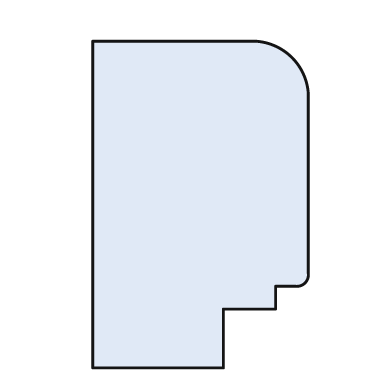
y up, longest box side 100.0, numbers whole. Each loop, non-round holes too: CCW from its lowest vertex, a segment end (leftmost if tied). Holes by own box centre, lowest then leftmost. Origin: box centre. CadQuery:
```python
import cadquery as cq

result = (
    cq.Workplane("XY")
    .moveTo(-33.0, -50.0)
    .lineTo(7.0, -50.0)
    .lineTo(7.0, -32.0)
    .lineTo(23.0, -32.0)
    .lineTo(23.0, -25.0)
    .lineTo(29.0, -25.0)
    .threePointArc((32.0, -24.0), (33.0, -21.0))
    .lineTo(33.0, 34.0)
    .threePointArc((28.0, 45.0), (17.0, 50.0))
    .lineTo(-33.0, 50.0)
    .close()
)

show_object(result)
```